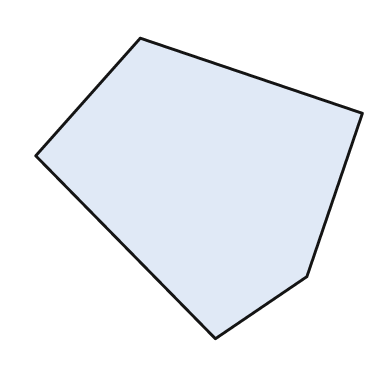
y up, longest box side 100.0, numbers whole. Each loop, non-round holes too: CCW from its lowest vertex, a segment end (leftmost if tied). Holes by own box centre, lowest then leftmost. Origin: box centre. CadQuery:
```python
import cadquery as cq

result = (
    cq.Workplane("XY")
    .moveTo(5.0, -46.0)
    .lineTo(33.0, -27.0)
    .lineTo(50.0, 23.0)
    .lineTo(-18.0, 46.0)
    .lineTo(-50.0, 10.0)
    .close()
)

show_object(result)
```